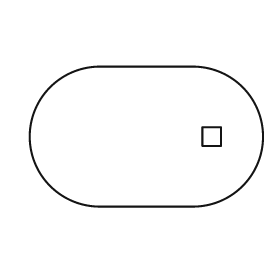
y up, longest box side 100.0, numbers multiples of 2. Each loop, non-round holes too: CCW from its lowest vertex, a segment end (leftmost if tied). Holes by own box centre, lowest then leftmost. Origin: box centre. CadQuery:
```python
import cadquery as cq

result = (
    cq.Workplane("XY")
    .moveTo(-20.0, -30.0)
    .lineTo(20.0, -30.0)
    .threePointArc((50.0, 0.0), (20.0, 30.0))
    .lineTo(-20.0, 30.0)
    .threePointArc((-50.0, 0.0), (-20.0, -30.0))
    .close()
    .moveTo(24.0, -4.0)
    .lineTo(32.0, -4.0)
    .lineTo(32.0, 4.0)
    .lineTo(24.0, 4.0)
    .close()
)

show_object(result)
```